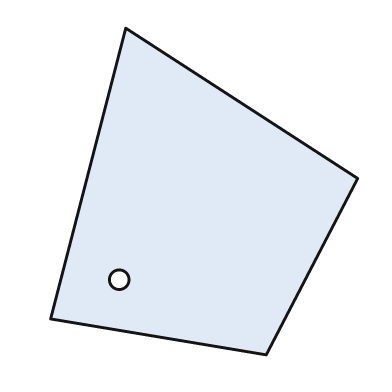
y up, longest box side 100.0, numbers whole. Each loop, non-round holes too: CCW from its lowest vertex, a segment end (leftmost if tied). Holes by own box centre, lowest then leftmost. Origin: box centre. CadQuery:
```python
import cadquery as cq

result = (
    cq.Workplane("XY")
    .moveTo(19.0, -50.0)
    .lineTo(47.0, 4.0)
    .lineTo(-24.0, 50.0)
    .lineTo(-47.0, -39.0)
    .close()
    .moveTo(-26.0, -27.0)
    .circle(3.0)
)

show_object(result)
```